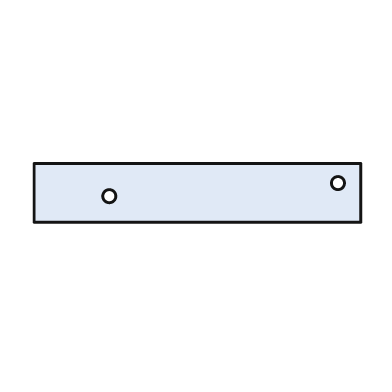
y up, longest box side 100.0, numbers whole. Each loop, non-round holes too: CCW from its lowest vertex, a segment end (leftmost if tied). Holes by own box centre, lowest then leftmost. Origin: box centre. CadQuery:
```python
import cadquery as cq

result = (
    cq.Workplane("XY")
    .moveTo(-50.0, -9.0)
    .lineTo(50.0, -9.0)
    .lineTo(50.0, 9.0)
    .lineTo(-50.0, 9.0)
    .close()
    .moveTo(-27.0, -1.0)
    .circle(2.0)
    .moveTo(43.0, 3.0)
    .circle(2.0)
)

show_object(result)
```